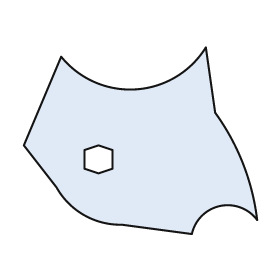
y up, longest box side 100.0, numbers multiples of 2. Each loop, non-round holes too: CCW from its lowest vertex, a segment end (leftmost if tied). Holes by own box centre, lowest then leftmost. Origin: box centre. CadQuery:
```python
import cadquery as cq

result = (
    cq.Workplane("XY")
    .moveTo(22.0, -40.0)
    .threePointArc((34.0, -28.0), (50.0, -34.0))
    .threePointArc((44.0, -10.0), (32.0, 12.0))
    .lineTo(28.0, 40.0)
    .threePointArc((-2.0, 22.0), (-34.0, 36.0))
    .lineTo(-50.0, -2.0)
    .lineTo(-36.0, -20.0)
    .threePointArc((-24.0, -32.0), (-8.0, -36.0))
    .close()
    .moveTo(-18.0, -14.0)
    .lineTo(-12.0, -12.0)
    .lineTo(-12.0, -4.0)
    .lineTo(-18.0, -2.0)
    .lineTo(-24.0, -4.0)
    .lineTo(-24.0, -12.0)
    .close()
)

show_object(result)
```